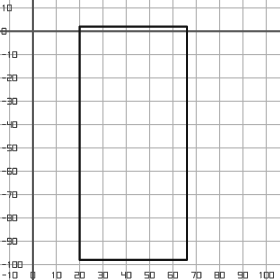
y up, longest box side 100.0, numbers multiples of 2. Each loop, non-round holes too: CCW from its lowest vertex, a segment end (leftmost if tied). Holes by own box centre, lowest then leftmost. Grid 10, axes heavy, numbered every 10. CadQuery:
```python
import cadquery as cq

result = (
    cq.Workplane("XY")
    .moveTo(20.0, -98.0)
    .lineTo(66.0, -98.0)
    .lineTo(66.0, 2.0)
    .lineTo(20.0, 2.0)
    .close()
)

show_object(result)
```